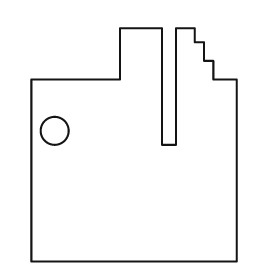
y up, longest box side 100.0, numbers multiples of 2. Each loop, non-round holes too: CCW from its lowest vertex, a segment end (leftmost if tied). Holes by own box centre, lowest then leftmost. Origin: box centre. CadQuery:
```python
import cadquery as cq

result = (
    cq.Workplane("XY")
    .moveTo(-44.0, -50.0)
    .lineTo(44.0, -50.0)
    .lineTo(44.0, 28.0)
    .lineTo(34.0, 28.0)
    .lineTo(34.0, 36.0)
    .lineTo(30.0, 36.0)
    .lineTo(30.0, 44.0)
    .lineTo(26.0, 44.0)
    .lineTo(26.0, 50.0)
    .lineTo(18.0, 50.0)
    .lineTo(18.0, 0.0)
    .lineTo(12.0, 0.0)
    .lineTo(12.0, 50.0)
    .lineTo(-6.0, 50.0)
    .lineTo(-6.0, 28.0)
    .lineTo(-44.0, 28.0)
    .close()
    .moveTo(-34.0, 6.0)
    .circle(6.0)
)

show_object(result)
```